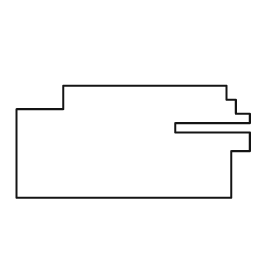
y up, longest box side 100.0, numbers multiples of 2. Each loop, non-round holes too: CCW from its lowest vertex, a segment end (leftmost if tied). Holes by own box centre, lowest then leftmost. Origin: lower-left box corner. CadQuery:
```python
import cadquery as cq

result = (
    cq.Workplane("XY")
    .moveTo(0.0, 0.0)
    .lineTo(92.0, 0.0)
    .lineTo(92.0, 20.0)
    .lineTo(100.0, 20.0)
    .lineTo(100.0, 28.0)
    .lineTo(68.0, 28.0)
    .lineTo(68.0, 32.0)
    .lineTo(100.0, 32.0)
    .lineTo(100.0, 36.0)
    .lineTo(94.0, 36.0)
    .lineTo(94.0, 42.0)
    .lineTo(90.0, 42.0)
    .lineTo(90.0, 48.0)
    .lineTo(20.0, 48.0)
    .lineTo(20.0, 38.0)
    .lineTo(0.0, 38.0)
    .close()
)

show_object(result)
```